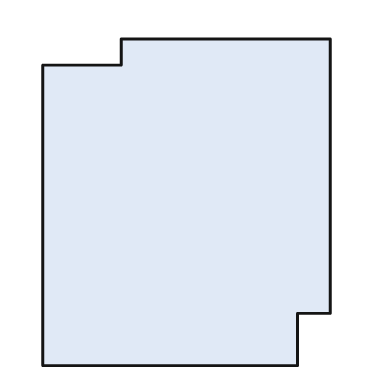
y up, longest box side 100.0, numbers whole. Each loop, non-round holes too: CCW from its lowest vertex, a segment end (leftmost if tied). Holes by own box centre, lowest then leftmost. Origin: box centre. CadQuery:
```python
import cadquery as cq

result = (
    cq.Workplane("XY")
    .moveTo(-44.0, -50.0)
    .lineTo(34.0, -50.0)
    .lineTo(34.0, -34.0)
    .lineTo(44.0, -34.0)
    .lineTo(44.0, 50.0)
    .lineTo(-20.0, 50.0)
    .lineTo(-20.0, 42.0)
    .lineTo(-44.0, 42.0)
    .close()
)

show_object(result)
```